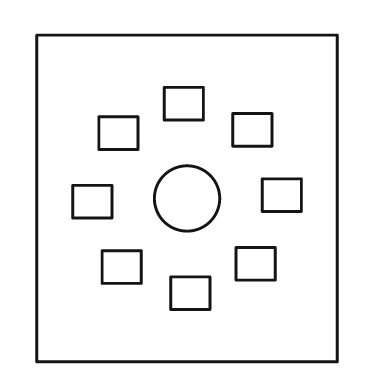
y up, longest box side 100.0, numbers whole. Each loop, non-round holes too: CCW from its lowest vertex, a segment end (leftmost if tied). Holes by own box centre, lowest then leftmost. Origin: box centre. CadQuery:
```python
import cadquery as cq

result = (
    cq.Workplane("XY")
    .moveTo(-46.0, -50.0)
    .lineTo(46.0, -50.0)
    .lineTo(46.0, 50.0)
    .lineTo(-46.0, 50.0)
    .close()
    .moveTo(-5.0, -34.0)
    .lineTo(7.0, -34.0)
    .lineTo(7.0, -24.0)
    .lineTo(-5.0, -24.0)
    .close()
    .moveTo(-26.0, -26.0)
    .lineTo(-14.0, -26.0)
    .lineTo(-14.0, -16.0)
    .lineTo(-26.0, -16.0)
    .close()
    .moveTo(15.0, -25.0)
    .lineTo(27.0, -25.0)
    .lineTo(27.0, -15.0)
    .lineTo(15.0, -15.0)
    .close()
    .moveTo(-35.0, -6.0)
    .lineTo(-23.0, -6.0)
    .lineTo(-23.0, 4.0)
    .lineTo(-35.0, 4.0)
    .close()
    .moveTo(0.0, 0.0)
    .circle(10.0)
    .moveTo(23.0, -4.0)
    .lineTo(35.0, -4.0)
    .lineTo(35.0, 6.0)
    .lineTo(23.0, 6.0)
    .close()
    .moveTo(-27.0, 15.0)
    .lineTo(-15.0, 15.0)
    .lineTo(-15.0, 25.0)
    .lineTo(-27.0, 25.0)
    .close()
    .moveTo(14.0, 16.0)
    .lineTo(26.0, 16.0)
    .lineTo(26.0, 26.0)
    .lineTo(14.0, 26.0)
    .close()
    .moveTo(-7.0, 24.0)
    .lineTo(5.0, 24.0)
    .lineTo(5.0, 34.0)
    .lineTo(-7.0, 34.0)
    .close()
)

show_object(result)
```